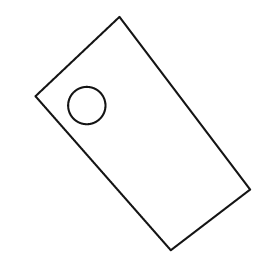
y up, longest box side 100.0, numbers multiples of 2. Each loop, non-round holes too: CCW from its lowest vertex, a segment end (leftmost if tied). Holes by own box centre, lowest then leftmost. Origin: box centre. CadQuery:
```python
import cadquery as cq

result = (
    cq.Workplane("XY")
    .moveTo(12.0, -50.0)
    .lineTo(46.0, -24.0)
    .lineTo(-10.0, 50.0)
    .lineTo(-46.0, 16.0)
    .close()
    .moveTo(-24.0, 12.0)
    .circle(8.0)
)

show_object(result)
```